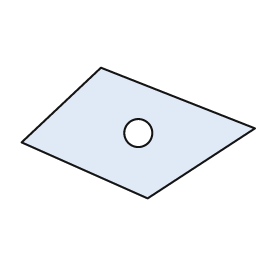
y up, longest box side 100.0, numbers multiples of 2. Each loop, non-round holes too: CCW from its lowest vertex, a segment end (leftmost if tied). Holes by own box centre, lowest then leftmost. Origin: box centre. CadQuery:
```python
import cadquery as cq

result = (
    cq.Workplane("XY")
    .moveTo(4.0, -28.0)
    .lineTo(50.0, 2.0)
    .lineTo(-16.0, 28.0)
    .lineTo(-50.0, -4.0)
    .close()
    .moveTo(0.0, 0.0)
    .circle(6.0)
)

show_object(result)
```